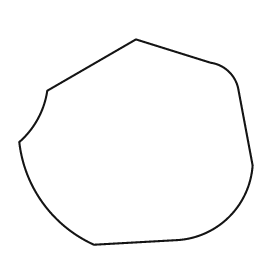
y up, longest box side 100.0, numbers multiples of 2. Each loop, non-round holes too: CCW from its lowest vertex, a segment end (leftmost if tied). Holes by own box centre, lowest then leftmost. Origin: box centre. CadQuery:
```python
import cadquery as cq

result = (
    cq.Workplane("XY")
    .moveTo(-18.0, -44.0)
    .lineTo(18.0, -42.0)
    .threePointArc((40.0, -32.0), (50.0, -10.0))
    .lineTo(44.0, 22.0)
    .threePointArc((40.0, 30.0), (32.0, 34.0))
    .lineTo(0.0, 44.0)
    .lineTo(-38.0, 22.0)
    .threePointArc((-42.0, 10.0), (-50.0, 0.0))
    .threePointArc((-40.0, -26.0), (-18.0, -44.0))
    .close()
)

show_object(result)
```